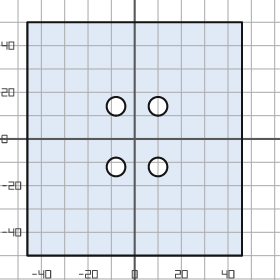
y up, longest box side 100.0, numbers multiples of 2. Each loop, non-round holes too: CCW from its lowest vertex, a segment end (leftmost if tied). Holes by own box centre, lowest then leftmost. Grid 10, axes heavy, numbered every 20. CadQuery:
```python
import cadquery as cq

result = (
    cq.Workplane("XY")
    .moveTo(-46.0, -50.0)
    .lineTo(46.0, -50.0)
    .lineTo(46.0, 50.0)
    .lineTo(-46.0, 50.0)
    .close()
    .moveTo(-8.0, -12.0)
    .circle(4.0)
    .moveTo(10.0, -12.0)
    .circle(4.0)
    .moveTo(-8.0, 14.0)
    .circle(4.0)
    .moveTo(10.0, 14.0)
    .circle(4.0)
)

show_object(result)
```